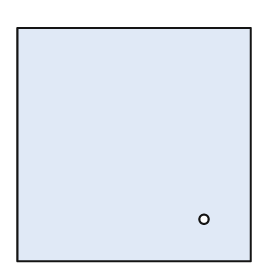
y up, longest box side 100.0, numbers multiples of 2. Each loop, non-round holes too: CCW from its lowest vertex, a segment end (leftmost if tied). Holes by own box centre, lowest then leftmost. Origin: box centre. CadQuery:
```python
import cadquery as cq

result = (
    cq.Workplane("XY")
    .moveTo(-50.0, -50.0)
    .lineTo(50.0, -50.0)
    .lineTo(50.0, 50.0)
    .lineTo(-50.0, 50.0)
    .close()
    .moveTo(30.0, -32.0)
    .circle(2.0)
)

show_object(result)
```